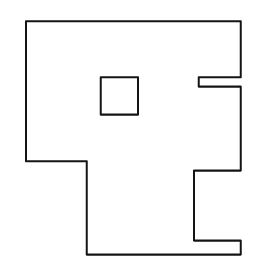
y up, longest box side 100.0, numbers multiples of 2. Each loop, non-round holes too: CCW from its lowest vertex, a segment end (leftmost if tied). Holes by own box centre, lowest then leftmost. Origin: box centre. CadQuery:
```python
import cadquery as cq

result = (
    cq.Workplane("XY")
    .moveTo(-20.0, -50.0)
    .lineTo(46.0, -50.0)
    .lineTo(46.0, -44.0)
    .lineTo(26.0, -44.0)
    .lineTo(26.0, -14.0)
    .lineTo(46.0, -14.0)
    .lineTo(46.0, 22.0)
    .lineTo(28.0, 22.0)
    .lineTo(28.0, 26.0)
    .lineTo(46.0, 26.0)
    .lineTo(46.0, 50.0)
    .lineTo(-46.0, 50.0)
    .lineTo(-46.0, -10.0)
    .lineTo(-20.0, -10.0)
    .close()
    .moveTo(-14.0, 10.0)
    .lineTo(2.0, 10.0)
    .lineTo(2.0, 26.0)
    .lineTo(-14.0, 26.0)
    .close()
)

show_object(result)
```